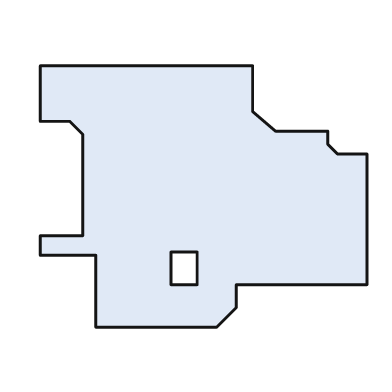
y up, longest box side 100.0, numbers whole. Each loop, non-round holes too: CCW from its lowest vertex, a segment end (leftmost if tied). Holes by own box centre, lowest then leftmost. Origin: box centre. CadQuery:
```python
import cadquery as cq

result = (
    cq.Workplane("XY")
    .moveTo(-33.0, -40.0)
    .lineTo(4.0, -40.0)
    .lineTo(10.0, -34.0)
    .lineTo(10.0, -27.0)
    .lineTo(50.0, -27.0)
    .lineTo(50.0, 13.0)
    .lineTo(41.0, 13.0)
    .lineTo(38.0, 16.0)
    .lineTo(38.0, 20.0)
    .lineTo(22.0, 20.0)
    .lineTo(15.0, 26.0)
    .lineTo(15.0, 40.0)
    .lineTo(-50.0, 40.0)
    .lineTo(-50.0, 23.0)
    .lineTo(-41.0, 23.0)
    .lineTo(-37.0, 19.0)
    .lineTo(-37.0, -12.0)
    .lineTo(-50.0, -12.0)
    .lineTo(-50.0, -18.0)
    .lineTo(-33.0, -18.0)
    .close()
    .moveTo(-10.0, -27.0)
    .lineTo(-2.0, -27.0)
    .lineTo(-2.0, -17.0)
    .lineTo(-10.0, -17.0)
    .close()
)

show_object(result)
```